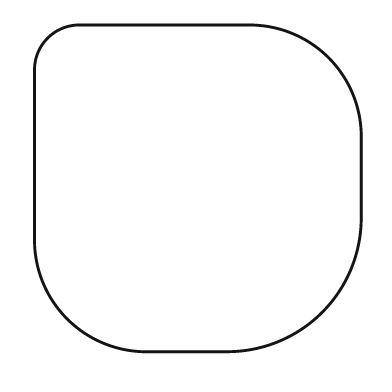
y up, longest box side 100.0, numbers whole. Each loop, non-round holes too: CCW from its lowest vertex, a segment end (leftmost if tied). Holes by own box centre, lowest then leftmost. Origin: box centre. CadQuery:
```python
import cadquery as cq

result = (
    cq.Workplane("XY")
    .moveTo(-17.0, -50.0)
    .lineTo(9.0, -50.0)
    .threePointArc((38.0, -38.0), (50.0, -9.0))
    .lineTo(50.0, 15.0)
    .threePointArc((40.0, 40.0), (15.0, 50.0))
    .lineTo(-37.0, 50.0)
    .threePointArc((-46.0, 46.0), (-50.0, 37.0))
    .lineTo(-50.0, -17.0)
    .threePointArc((-40.0, -40.0), (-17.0, -50.0))
    .close()
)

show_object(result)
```